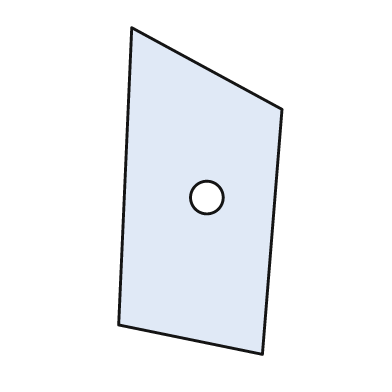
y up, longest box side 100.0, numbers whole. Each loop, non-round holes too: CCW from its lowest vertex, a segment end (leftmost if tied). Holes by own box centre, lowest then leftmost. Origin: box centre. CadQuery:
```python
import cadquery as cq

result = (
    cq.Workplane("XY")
    .moveTo(19.0, -50.0)
    .lineTo(25.0, 25.0)
    .lineTo(-21.0, 50.0)
    .lineTo(-25.0, -41.0)
    .close()
    .moveTo(2.0, -2.0)
    .circle(5.0)
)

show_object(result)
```